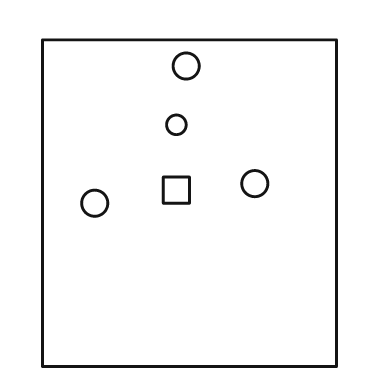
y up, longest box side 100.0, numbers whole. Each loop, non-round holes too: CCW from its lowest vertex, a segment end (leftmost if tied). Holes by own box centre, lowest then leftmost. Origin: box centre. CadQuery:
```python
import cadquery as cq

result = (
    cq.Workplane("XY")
    .moveTo(-45.0, -50.0)
    .lineTo(45.0, -50.0)
    .lineTo(45.0, 50.0)
    .lineTo(-45.0, 50.0)
    .close()
    .moveTo(-29.0, 0.0)
    .circle(4.0)
    .moveTo(-8.0, 0.0)
    .lineTo(0.0, 0.0)
    .lineTo(0.0, 8.0)
    .lineTo(-8.0, 8.0)
    .close()
    .moveTo(20.0, 6.0)
    .circle(4.0)
    .moveTo(-4.0, 24.0)
    .circle(3.0)
    .moveTo(-1.0, 42.0)
    .circle(4.0)
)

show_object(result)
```